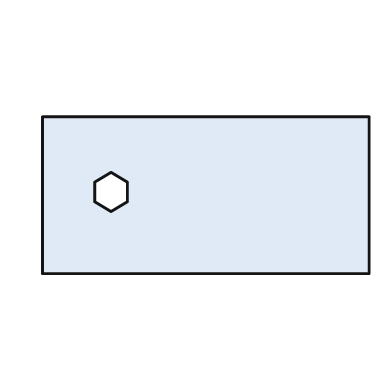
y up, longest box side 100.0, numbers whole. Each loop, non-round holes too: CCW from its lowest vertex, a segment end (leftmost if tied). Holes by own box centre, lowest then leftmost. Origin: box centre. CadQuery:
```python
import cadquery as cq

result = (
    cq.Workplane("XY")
    .moveTo(-50.0, -24.0)
    .lineTo(50.0, -24.0)
    .lineTo(50.0, 24.0)
    .lineTo(-50.0, 24.0)
    .close()
    .moveTo(-29.0, -5.0)
    .lineTo(-24.0, -2.0)
    .lineTo(-24.0, 4.0)
    .lineTo(-29.0, 7.0)
    .lineTo(-34.0, 4.0)
    .lineTo(-34.0, -2.0)
    .close()
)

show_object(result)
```